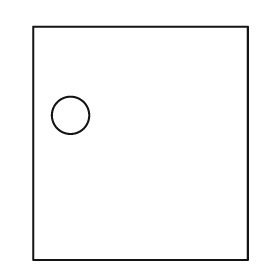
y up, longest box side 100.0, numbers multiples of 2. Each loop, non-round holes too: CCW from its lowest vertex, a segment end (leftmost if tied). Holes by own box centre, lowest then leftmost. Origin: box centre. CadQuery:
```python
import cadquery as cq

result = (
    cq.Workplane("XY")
    .moveTo(-46.0, -50.0)
    .lineTo(46.0, -50.0)
    .lineTo(46.0, 50.0)
    .lineTo(-46.0, 50.0)
    .close()
    .moveTo(-30.0, 12.0)
    .circle(8.0)
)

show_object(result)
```